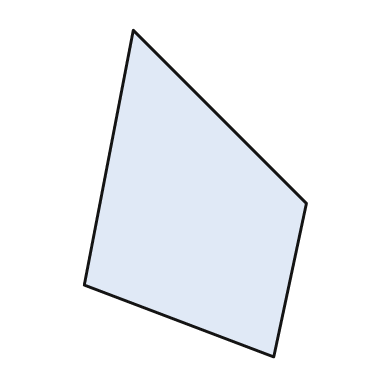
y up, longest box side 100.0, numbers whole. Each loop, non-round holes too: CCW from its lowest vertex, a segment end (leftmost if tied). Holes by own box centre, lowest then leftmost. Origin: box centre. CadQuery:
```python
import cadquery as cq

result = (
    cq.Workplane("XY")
    .moveTo(24.0, -50.0)
    .lineTo(34.0, -3.0)
    .lineTo(-19.0, 50.0)
    .lineTo(-34.0, -28.0)
    .close()
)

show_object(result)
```